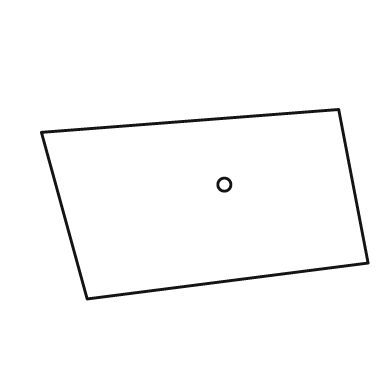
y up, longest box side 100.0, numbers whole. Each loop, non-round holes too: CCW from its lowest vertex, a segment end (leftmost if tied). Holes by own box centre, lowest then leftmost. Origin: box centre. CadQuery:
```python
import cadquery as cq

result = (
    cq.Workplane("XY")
    .moveTo(-36.0, -29.0)
    .lineTo(50.0, -18.0)
    .lineTo(41.0, 29.0)
    .lineTo(-50.0, 22.0)
    .close()
    .moveTo(6.0, 6.0)
    .circle(2.0)
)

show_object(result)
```